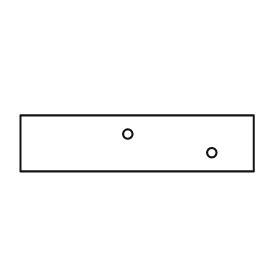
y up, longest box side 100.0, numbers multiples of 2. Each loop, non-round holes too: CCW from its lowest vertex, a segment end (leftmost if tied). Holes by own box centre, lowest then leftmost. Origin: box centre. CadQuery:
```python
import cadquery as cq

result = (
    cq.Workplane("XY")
    .moveTo(-50.0, -12.0)
    .lineTo(50.0, -12.0)
    .lineTo(50.0, 12.0)
    .lineTo(-50.0, 12.0)
    .close()
    .moveTo(32.0, -4.0)
    .circle(2.0)
    .moveTo(-4.0, 4.0)
    .circle(2.0)
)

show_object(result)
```